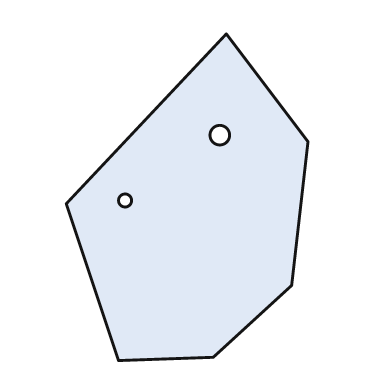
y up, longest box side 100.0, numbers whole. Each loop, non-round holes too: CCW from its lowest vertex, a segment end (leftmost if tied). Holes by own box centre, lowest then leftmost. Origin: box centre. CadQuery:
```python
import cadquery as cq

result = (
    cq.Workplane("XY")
    .moveTo(-21.0, -50.0)
    .lineTo(8.0, -49.0)
    .lineTo(32.0, -27.0)
    .lineTo(37.0, 17.0)
    .lineTo(12.0, 50.0)
    .lineTo(-37.0, -2.0)
    .close()
    .moveTo(-19.0, -1.0)
    .circle(2.0)
    .moveTo(10.0, 19.0)
    .circle(3.0)
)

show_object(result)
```